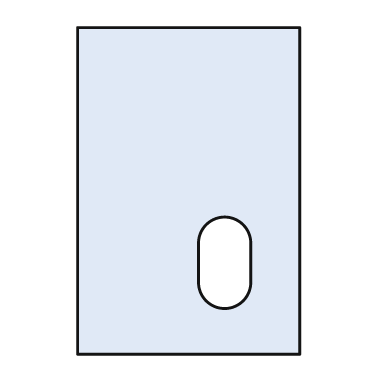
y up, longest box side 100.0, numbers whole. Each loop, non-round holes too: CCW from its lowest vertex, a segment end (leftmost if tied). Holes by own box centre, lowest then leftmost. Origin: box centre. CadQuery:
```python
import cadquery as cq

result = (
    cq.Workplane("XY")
    .moveTo(-34.0, -50.0)
    .lineTo(34.0, -50.0)
    .lineTo(34.0, 50.0)
    .lineTo(-34.0, 50.0)
    .close()
    .moveTo(3.0, -28.0)
    .threePointArc((11.0, -36.0), (19.0, -28.0))
    .lineTo(19.0, -16.0)
    .threePointArc((11.0, -8.0), (3.0, -16.0))
    .close()
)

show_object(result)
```